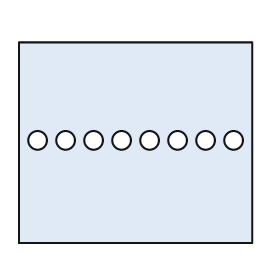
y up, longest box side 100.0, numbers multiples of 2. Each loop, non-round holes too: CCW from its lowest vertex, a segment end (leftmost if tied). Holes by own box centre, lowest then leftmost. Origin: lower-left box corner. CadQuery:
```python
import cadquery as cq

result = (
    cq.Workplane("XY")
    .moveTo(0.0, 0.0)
    .lineTo(100.0, 0.0)
    .lineTo(100.0, 86.0)
    .lineTo(0.0, 86.0)
    .close()
    .moveTo(8.0, 44.0)
    .circle(4.0)
    .moveTo(20.0, 44.0)
    .circle(4.0)
    .moveTo(32.0, 44.0)
    .circle(4.0)
    .moveTo(44.0, 44.0)
    .circle(4.0)
    .moveTo(56.0, 44.0)
    .circle(4.0)
    .moveTo(68.0, 44.0)
    .circle(4.0)
    .moveTo(80.0, 44.0)
    .circle(4.0)
    .moveTo(92.0, 44.0)
    .circle(4.0)
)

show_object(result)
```